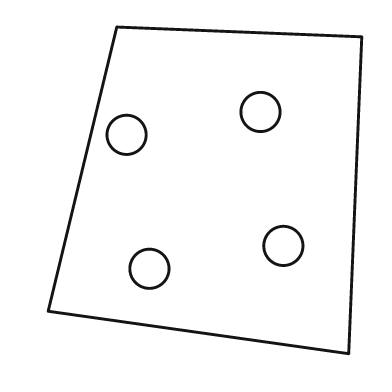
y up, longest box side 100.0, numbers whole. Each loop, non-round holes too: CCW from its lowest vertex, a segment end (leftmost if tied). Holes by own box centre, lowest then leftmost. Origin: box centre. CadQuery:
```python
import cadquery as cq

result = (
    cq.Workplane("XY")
    .moveTo(44.0, -50.0)
    .lineTo(48.0, 47.0)
    .lineTo(-27.0, 50.0)
    .lineTo(-48.0, -37.0)
    .close()
    .moveTo(-17.0, -24.0)
    .circle(6.0)
    .moveTo(24.0, -17.0)
    .circle(6.0)
    .moveTo(-24.0, 17.0)
    .circle(6.0)
    .moveTo(17.0, 24.0)
    .circle(6.0)
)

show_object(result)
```